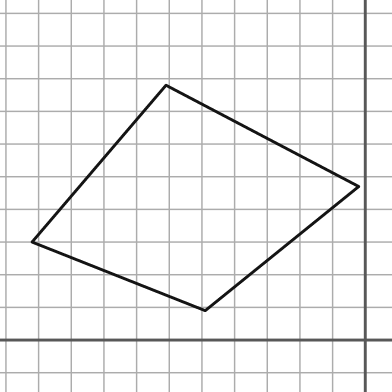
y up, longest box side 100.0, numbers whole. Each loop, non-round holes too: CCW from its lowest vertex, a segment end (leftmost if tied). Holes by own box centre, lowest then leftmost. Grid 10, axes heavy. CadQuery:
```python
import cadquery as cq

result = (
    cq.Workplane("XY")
    .moveTo(-49.0, 9.0)
    .lineTo(-2.0, 47.0)
    .lineTo(-61.0, 78.0)
    .lineTo(-102.0, 30.0)
    .close()
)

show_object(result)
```